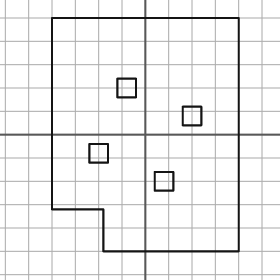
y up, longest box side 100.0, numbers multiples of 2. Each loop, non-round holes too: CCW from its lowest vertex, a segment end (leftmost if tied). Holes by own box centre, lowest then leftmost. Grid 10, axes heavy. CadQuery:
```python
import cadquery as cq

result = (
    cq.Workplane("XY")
    .moveTo(-18.0, -50.0)
    .lineTo(40.0, -50.0)
    .lineTo(40.0, 50.0)
    .lineTo(-40.0, 50.0)
    .lineTo(-40.0, -32.0)
    .lineTo(-18.0, -32.0)
    .close()
    .moveTo(4.0, -24.0)
    .lineTo(12.0, -24.0)
    .lineTo(12.0, -16.0)
    .lineTo(4.0, -16.0)
    .close()
    .moveTo(-24.0, -12.0)
    .lineTo(-16.0, -12.0)
    .lineTo(-16.0, -4.0)
    .lineTo(-24.0, -4.0)
    .close()
    .moveTo(16.0, 4.0)
    .lineTo(24.0, 4.0)
    .lineTo(24.0, 12.0)
    .lineTo(16.0, 12.0)
    .close()
    .moveTo(-12.0, 16.0)
    .lineTo(-4.0, 16.0)
    .lineTo(-4.0, 24.0)
    .lineTo(-12.0, 24.0)
    .close()
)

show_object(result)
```